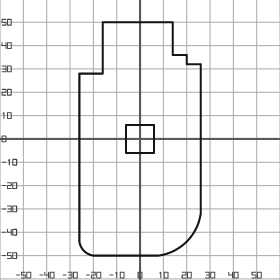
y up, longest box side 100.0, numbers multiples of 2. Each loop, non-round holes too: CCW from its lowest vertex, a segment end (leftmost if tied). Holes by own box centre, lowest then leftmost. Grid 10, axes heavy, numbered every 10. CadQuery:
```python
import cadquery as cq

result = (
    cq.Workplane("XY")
    .moveTo(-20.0, -50.0)
    .lineTo(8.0, -50.0)
    .threePointArc((20.0, -44.0), (26.0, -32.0))
    .lineTo(26.0, 32.0)
    .lineTo(20.0, 32.0)
    .lineTo(20.0, 36.0)
    .lineTo(14.0, 36.0)
    .lineTo(14.0, 50.0)
    .lineTo(-16.0, 50.0)
    .lineTo(-16.0, 28.0)
    .lineTo(-26.0, 28.0)
    .lineTo(-26.0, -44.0)
    .threePointArc((-24.0, -48.0), (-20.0, -50.0))
    .close()
    .moveTo(-6.0, -6.0)
    .lineTo(6.0, -6.0)
    .lineTo(6.0, 6.0)
    .lineTo(-6.0, 6.0)
    .close()
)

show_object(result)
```